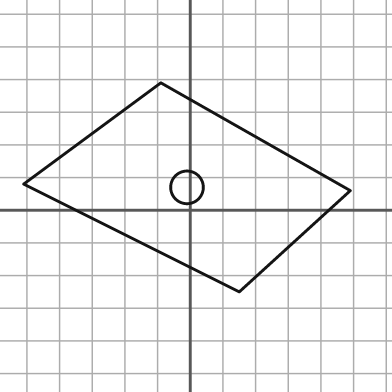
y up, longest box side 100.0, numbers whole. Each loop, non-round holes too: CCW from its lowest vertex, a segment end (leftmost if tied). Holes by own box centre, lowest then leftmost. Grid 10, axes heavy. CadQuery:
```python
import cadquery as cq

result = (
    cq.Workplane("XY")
    .moveTo(15.0, -25.0)
    .lineTo(49.0, 6.0)
    .lineTo(-9.0, 39.0)
    .lineTo(-51.0, 8.0)
    .close()
    .moveTo(-1.0, 7.0)
    .circle(5.0)
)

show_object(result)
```